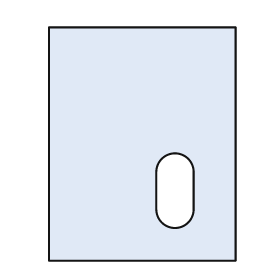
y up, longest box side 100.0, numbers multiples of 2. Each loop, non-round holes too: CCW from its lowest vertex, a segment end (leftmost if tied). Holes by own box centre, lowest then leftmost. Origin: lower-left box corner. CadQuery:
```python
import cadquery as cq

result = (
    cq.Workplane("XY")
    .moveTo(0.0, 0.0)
    .lineTo(80.0, 0.0)
    .lineTo(80.0, 100.0)
    .lineTo(0.0, 100.0)
    .close()
    .moveTo(46.0, 22.0)
    .threePointArc((54.0, 14.0), (62.0, 22.0))
    .lineTo(62.0, 38.0)
    .threePointArc((54.0, 46.0), (46.0, 38.0))
    .close()
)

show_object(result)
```